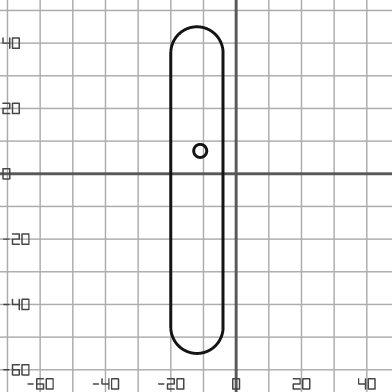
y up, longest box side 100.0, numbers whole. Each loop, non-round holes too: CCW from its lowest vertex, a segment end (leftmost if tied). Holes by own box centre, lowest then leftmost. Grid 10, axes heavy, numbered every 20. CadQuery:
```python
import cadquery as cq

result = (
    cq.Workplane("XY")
    .moveTo(-20.0, -47.0)
    .threePointArc((-12.0, -55.0), (-4.0, -47.0))
    .lineTo(-4.0, 37.0)
    .threePointArc((-12.0, 45.0), (-20.0, 37.0))
    .close()
    .moveTo(-11.0, 7.0)
    .circle(2.0)
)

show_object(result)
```